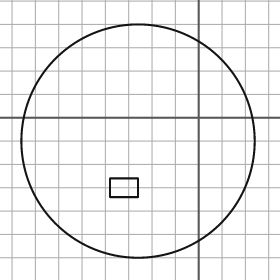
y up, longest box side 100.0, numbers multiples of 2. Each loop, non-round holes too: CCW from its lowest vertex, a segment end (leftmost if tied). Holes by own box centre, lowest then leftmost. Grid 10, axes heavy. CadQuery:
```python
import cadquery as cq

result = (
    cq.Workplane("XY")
    .moveTo(-26.0, -10.0)
    .circle(50.0)
    .moveTo(-38.0, -34.0)
    .lineTo(-26.0, -34.0)
    .lineTo(-26.0, -26.0)
    .lineTo(-38.0, -26.0)
    .close()
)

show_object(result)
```